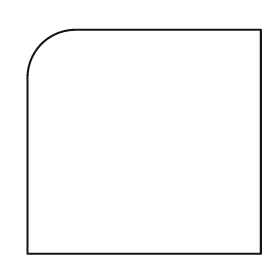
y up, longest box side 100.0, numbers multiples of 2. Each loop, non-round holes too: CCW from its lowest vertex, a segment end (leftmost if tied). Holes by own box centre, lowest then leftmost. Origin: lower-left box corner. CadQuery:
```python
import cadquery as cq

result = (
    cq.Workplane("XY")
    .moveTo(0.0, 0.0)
    .lineTo(100.0, 0.0)
    .lineTo(100.0, 96.0)
    .lineTo(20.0, 96.0)
    .threePointArc((6.0, 90.0), (0.0, 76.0))
    .close()
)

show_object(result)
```